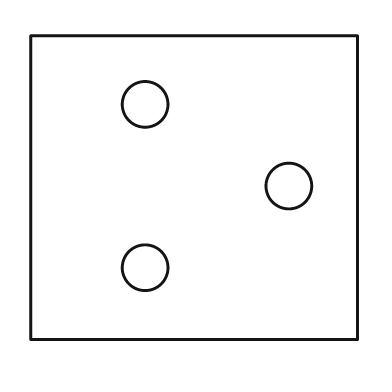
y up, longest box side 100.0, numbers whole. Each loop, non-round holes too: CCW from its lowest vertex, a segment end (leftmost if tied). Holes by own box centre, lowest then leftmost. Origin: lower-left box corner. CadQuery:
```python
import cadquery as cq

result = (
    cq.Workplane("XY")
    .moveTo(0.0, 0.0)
    .lineTo(100.0, 0.0)
    .lineTo(100.0, 93.0)
    .lineTo(0.0, 93.0)
    .close()
    .moveTo(35.0, 22.0)
    .circle(7.0)
    .moveTo(79.0, 47.0)
    .circle(7.0)
    .moveTo(35.0, 72.0)
    .circle(7.0)
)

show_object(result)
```